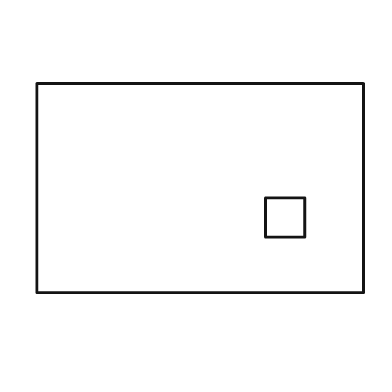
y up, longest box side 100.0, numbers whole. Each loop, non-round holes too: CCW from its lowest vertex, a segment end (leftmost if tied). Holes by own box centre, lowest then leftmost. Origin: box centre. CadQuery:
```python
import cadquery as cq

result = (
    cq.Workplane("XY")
    .moveTo(-50.0, -32.0)
    .lineTo(50.0, -32.0)
    .lineTo(50.0, 32.0)
    .lineTo(-50.0, 32.0)
    .close()
    .moveTo(20.0, -15.0)
    .lineTo(32.0, -15.0)
    .lineTo(32.0, -3.0)
    .lineTo(20.0, -3.0)
    .close()
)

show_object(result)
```